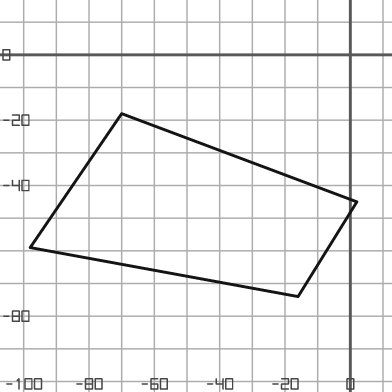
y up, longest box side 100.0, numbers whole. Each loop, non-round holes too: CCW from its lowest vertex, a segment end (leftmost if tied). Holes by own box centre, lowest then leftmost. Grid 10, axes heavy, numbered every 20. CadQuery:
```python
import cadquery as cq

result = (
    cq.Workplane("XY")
    .moveTo(-16.0, -74.0)
    .lineTo(2.0, -45.0)
    .lineTo(-70.0, -18.0)
    .lineTo(-98.0, -59.0)
    .close()
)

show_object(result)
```